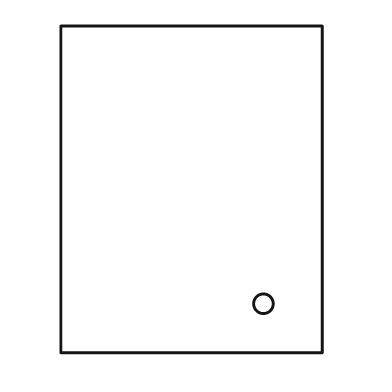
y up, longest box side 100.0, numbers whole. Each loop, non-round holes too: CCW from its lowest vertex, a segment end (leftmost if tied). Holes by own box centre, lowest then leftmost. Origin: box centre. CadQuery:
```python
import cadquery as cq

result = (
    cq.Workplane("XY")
    .moveTo(-40.0, -50.0)
    .lineTo(40.0, -50.0)
    .lineTo(40.0, 50.0)
    .lineTo(-40.0, 50.0)
    .close()
    .moveTo(22.0, -35.0)
    .circle(3.0)
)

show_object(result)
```